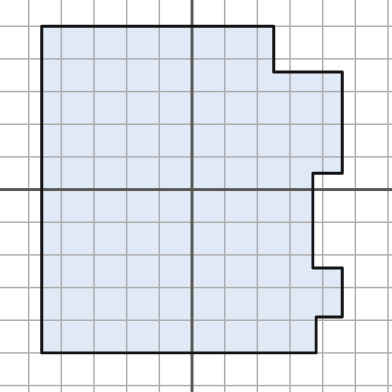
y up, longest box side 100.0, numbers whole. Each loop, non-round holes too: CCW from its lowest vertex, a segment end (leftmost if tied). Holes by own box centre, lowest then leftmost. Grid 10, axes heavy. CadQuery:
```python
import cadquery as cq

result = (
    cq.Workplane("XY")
    .moveTo(-46.0, -50.0)
    .lineTo(38.0, -50.0)
    .lineTo(38.0, -39.0)
    .lineTo(46.0, -39.0)
    .lineTo(46.0, -24.0)
    .lineTo(37.0, -24.0)
    .lineTo(37.0, 5.0)
    .lineTo(46.0, 5.0)
    .lineTo(46.0, 36.0)
    .lineTo(25.0, 36.0)
    .lineTo(25.0, 50.0)
    .lineTo(-46.0, 50.0)
    .close()
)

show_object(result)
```